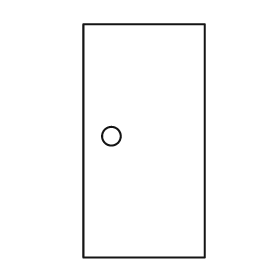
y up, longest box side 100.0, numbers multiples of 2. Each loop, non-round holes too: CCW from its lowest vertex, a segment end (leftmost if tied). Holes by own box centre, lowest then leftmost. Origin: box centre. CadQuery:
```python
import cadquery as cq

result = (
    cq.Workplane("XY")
    .moveTo(-26.0, -50.0)
    .lineTo(26.0, -50.0)
    .lineTo(26.0, 50.0)
    .lineTo(-26.0, 50.0)
    .close()
    .moveTo(-14.0, 2.0)
    .circle(4.0)
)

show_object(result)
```